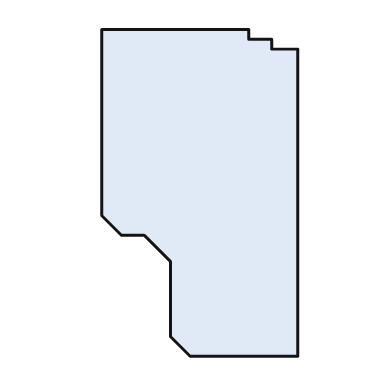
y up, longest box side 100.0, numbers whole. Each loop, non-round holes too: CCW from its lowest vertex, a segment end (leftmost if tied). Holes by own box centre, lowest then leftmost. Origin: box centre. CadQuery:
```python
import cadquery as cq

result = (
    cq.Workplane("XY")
    .moveTo(-3.0, -50.0)
    .lineTo(30.0, -50.0)
    .lineTo(30.0, 44.0)
    .lineTo(22.0, 44.0)
    .lineTo(22.0, 47.0)
    .lineTo(15.0, 47.0)
    .lineTo(15.0, 50.0)
    .lineTo(-30.0, 50.0)
    .lineTo(-30.0, -7.0)
    .lineTo(-24.0, -13.0)
    .lineTo(-17.0, -13.0)
    .lineTo(-9.0, -21.0)
    .lineTo(-9.0, -44.0)
    .close()
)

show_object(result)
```